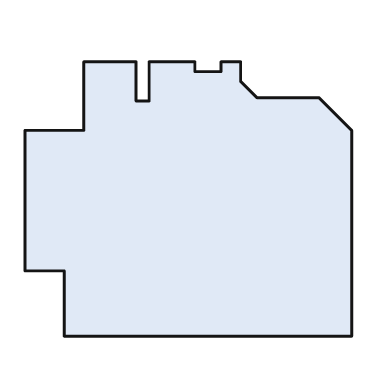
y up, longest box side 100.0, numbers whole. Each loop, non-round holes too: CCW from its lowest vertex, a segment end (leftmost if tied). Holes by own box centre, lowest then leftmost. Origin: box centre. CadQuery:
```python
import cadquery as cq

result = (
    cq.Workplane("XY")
    .moveTo(-38.0, -42.0)
    .lineTo(50.0, -42.0)
    .lineTo(50.0, 21.0)
    .lineTo(40.0, 31.0)
    .lineTo(21.0, 31.0)
    .lineTo(16.0, 36.0)
    .lineTo(16.0, 42.0)
    .lineTo(10.0, 42.0)
    .lineTo(10.0, 39.0)
    .lineTo(2.0, 39.0)
    .lineTo(2.0, 42.0)
    .lineTo(-12.0, 42.0)
    .lineTo(-12.0, 30.0)
    .lineTo(-16.0, 30.0)
    .lineTo(-16.0, 42.0)
    .lineTo(-32.0, 42.0)
    .lineTo(-32.0, 21.0)
    .lineTo(-50.0, 21.0)
    .lineTo(-50.0, -22.0)
    .lineTo(-38.0, -22.0)
    .close()
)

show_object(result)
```